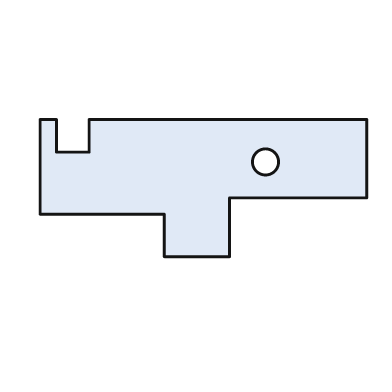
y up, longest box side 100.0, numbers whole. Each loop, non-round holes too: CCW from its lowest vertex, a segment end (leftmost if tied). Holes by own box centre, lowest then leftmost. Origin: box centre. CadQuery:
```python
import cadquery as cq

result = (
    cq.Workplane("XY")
    .moveTo(-12.0, -21.0)
    .lineTo(8.0, -21.0)
    .lineTo(8.0, -3.0)
    .lineTo(50.0, -3.0)
    .lineTo(50.0, 21.0)
    .lineTo(-35.0, 21.0)
    .lineTo(-35.0, 11.0)
    .lineTo(-45.0, 11.0)
    .lineTo(-45.0, 21.0)
    .lineTo(-50.0, 21.0)
    .lineTo(-50.0, -8.0)
    .lineTo(-12.0, -8.0)
    .close()
    .moveTo(19.0, 8.0)
    .circle(4.0)
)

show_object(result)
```